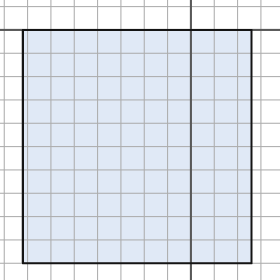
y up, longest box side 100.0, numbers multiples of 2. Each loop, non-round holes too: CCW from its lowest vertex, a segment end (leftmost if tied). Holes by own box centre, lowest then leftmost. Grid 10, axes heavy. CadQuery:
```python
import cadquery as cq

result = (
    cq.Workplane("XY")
    .moveTo(-72.0, -100.0)
    .lineTo(26.0, -100.0)
    .lineTo(26.0, 0.0)
    .lineTo(-72.0, 0.0)
    .close()
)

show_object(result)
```